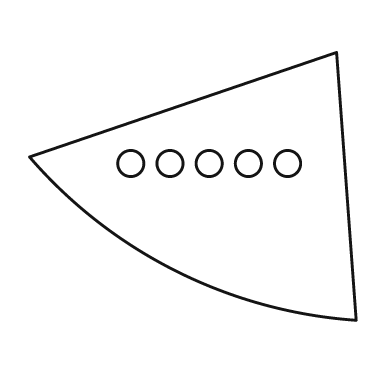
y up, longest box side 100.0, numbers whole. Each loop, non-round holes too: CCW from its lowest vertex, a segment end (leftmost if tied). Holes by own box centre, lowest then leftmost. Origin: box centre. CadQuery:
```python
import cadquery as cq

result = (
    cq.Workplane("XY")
    .moveTo(50.0, -41.0)
    .lineTo(44.0, 41.0)
    .lineTo(-50.0, 9.0)
    .threePointArc((-5.0, -26.0), (50.0, -41.0))
    .close()
    .moveTo(-19.0, 7.0)
    .circle(4.0)
    .moveTo(-7.0, 7.0)
    .circle(4.0)
    .moveTo(5.0, 7.0)
    .circle(4.0)
    .moveTo(17.0, 7.0)
    .circle(4.0)
    .moveTo(29.0, 7.0)
    .circle(4.0)
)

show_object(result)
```